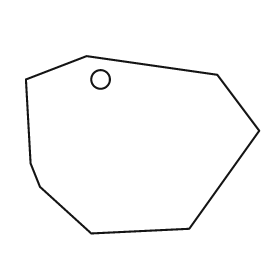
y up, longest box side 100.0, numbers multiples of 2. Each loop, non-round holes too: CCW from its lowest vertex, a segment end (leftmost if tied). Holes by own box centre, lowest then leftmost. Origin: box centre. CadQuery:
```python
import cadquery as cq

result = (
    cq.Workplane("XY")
    .moveTo(-22.0, -38.0)
    .lineTo(20.0, -36.0)
    .lineTo(50.0, 6.0)
    .lineTo(32.0, 30.0)
    .lineTo(-24.0, 38.0)
    .lineTo(-50.0, 28.0)
    .lineTo(-48.0, -8.0)
    .lineTo(-44.0, -18.0)
    .close()
    .moveTo(-18.0, 28.0)
    .circle(4.0)
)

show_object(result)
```